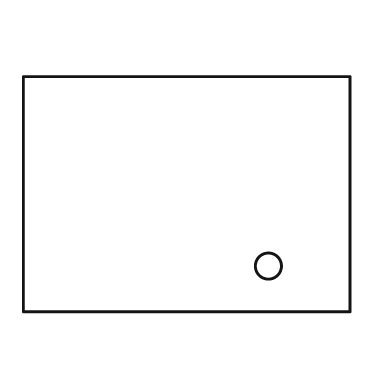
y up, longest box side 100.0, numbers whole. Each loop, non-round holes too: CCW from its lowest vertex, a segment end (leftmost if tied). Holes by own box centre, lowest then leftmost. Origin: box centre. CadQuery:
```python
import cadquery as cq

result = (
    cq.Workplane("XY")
    .moveTo(-50.0, -36.0)
    .lineTo(50.0, -36.0)
    .lineTo(50.0, 36.0)
    .lineTo(-50.0, 36.0)
    .close()
    .moveTo(25.0, -22.0)
    .circle(4.0)
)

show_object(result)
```